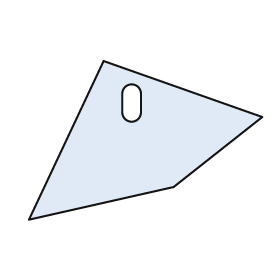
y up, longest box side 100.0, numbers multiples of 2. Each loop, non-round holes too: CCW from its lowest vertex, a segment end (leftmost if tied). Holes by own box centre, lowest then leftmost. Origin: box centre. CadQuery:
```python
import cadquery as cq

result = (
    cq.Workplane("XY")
    .moveTo(-50.0, -34.0)
    .lineTo(12.0, -20.0)
    .lineTo(50.0, 10.0)
    .lineTo(-18.0, 34.0)
    .close()
    .moveTo(-10.0, 12.0)
    .threePointArc((-6.0, 8.0), (-2.0, 12.0))
    .lineTo(-2.0, 20.0)
    .threePointArc((-6.0, 24.0), (-10.0, 20.0))
    .close()
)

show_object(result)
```